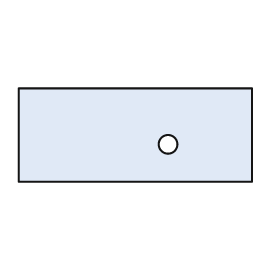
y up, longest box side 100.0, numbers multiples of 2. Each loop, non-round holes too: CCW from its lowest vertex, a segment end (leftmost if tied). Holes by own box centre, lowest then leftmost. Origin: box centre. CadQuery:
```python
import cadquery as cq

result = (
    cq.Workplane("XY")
    .moveTo(-50.0, -20.0)
    .lineTo(50.0, -20.0)
    .lineTo(50.0, 20.0)
    .lineTo(-50.0, 20.0)
    .close()
    .moveTo(14.0, -4.0)
    .circle(4.0)
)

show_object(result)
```